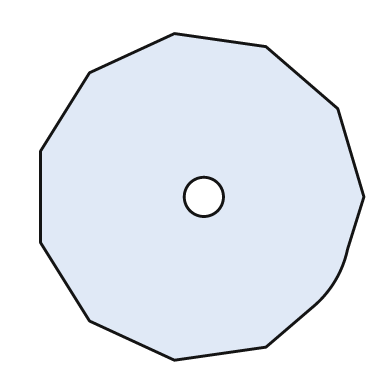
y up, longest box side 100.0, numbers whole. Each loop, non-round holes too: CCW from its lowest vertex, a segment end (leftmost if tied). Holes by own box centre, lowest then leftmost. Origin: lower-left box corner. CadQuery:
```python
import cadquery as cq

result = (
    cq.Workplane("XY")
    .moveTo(41.0, 0.0)
    .lineTo(69.0, 4.0)
    .lineTo(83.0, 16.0)
    .threePointArc((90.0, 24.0), (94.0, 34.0))
    .lineTo(99.0, 50.0)
    .lineTo(91.0, 77.0)
    .lineTo(69.0, 96.0)
    .lineTo(41.0, 100.0)
    .lineTo(15.0, 88.0)
    .lineTo(0.0, 64.0)
    .lineTo(0.0, 36.0)
    .lineTo(15.0, 12.0)
    .close()
    .moveTo(50.0, 50.0)
    .circle(6.0)
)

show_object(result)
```